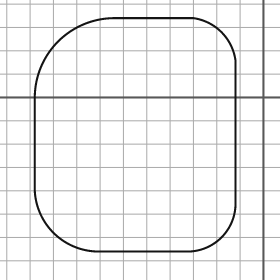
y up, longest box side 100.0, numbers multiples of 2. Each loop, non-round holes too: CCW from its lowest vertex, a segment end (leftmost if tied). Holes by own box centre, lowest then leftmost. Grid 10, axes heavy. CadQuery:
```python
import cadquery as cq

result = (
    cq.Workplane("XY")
    .moveTo(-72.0, -66.0)
    .lineTo(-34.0, -66.0)
    .threePointArc((-18.0, -60.0), (-12.0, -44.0))
    .lineTo(-12.0, 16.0)
    .threePointArc((-18.0, 28.0), (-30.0, 34.0))
    .lineTo(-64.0, 34.0)
    .threePointArc((-88.0, 24.0), (-98.0, 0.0))
    .lineTo(-98.0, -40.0)
    .threePointArc((-90.0, -58.0), (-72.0, -66.0))
    .close()
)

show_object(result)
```